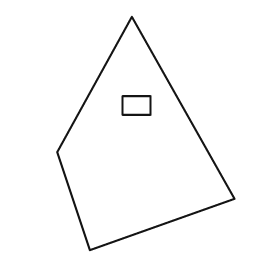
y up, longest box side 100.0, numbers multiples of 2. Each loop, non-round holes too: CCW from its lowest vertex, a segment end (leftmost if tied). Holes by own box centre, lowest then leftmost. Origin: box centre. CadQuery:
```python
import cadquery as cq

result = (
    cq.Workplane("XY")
    .moveTo(-24.0, -50.0)
    .lineTo(38.0, -28.0)
    .lineTo(-6.0, 50.0)
    .lineTo(-38.0, -8.0)
    .close()
    .moveTo(-10.0, 8.0)
    .lineTo(2.0, 8.0)
    .lineTo(2.0, 16.0)
    .lineTo(-10.0, 16.0)
    .close()
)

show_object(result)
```